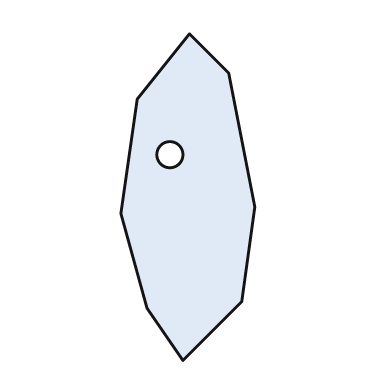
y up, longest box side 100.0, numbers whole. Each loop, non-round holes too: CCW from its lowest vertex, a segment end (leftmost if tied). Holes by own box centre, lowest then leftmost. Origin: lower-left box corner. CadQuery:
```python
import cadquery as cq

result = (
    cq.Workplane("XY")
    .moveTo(19.0, 0.0)
    .lineTo(37.0, 18.0)
    .lineTo(41.0, 47.0)
    .lineTo(33.0, 88.0)
    .lineTo(21.0, 100.0)
    .lineTo(5.0, 80.0)
    .lineTo(0.0, 45.0)
    .lineTo(8.0, 16.0)
    .close()
    .moveTo(15.0, 63.0)
    .circle(4.0)
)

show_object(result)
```